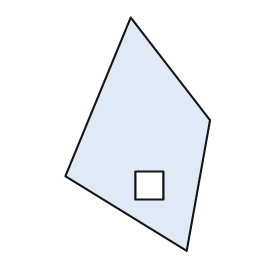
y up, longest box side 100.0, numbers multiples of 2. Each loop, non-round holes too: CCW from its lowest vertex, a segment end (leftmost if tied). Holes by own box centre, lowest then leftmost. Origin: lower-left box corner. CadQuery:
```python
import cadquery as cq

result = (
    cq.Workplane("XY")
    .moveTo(52.0, 0.0)
    .lineTo(62.0, 56.0)
    .lineTo(28.0, 100.0)
    .lineTo(0.0, 32.0)
    .close()
    .moveTo(30.0, 22.0)
    .lineTo(42.0, 22.0)
    .lineTo(42.0, 34.0)
    .lineTo(30.0, 34.0)
    .close()
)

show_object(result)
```